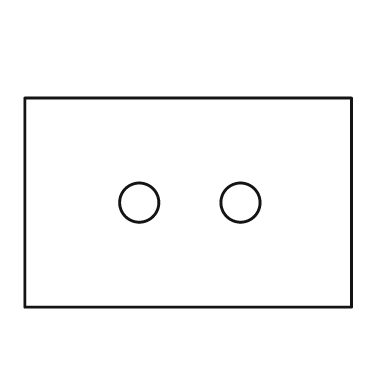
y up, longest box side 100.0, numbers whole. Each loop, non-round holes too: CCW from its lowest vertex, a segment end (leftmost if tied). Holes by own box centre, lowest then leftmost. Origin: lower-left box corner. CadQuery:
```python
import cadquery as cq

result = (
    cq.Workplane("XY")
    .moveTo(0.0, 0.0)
    .lineTo(100.0, 0.0)
    .lineTo(100.0, 64.0)
    .lineTo(0.0, 64.0)
    .close()
    .moveTo(35.0, 32.0)
    .circle(6.0)
    .moveTo(66.0, 32.0)
    .circle(6.0)
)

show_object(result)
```